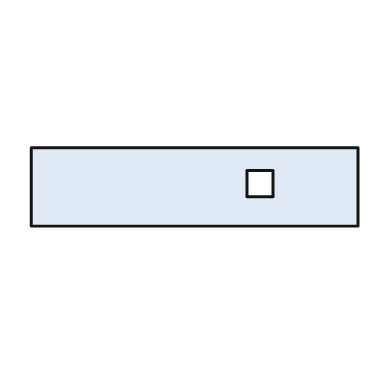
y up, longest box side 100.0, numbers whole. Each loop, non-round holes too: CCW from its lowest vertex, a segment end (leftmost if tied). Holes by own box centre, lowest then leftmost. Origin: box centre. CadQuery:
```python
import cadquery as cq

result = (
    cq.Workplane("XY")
    .moveTo(-50.0, -12.0)
    .lineTo(50.0, -12.0)
    .lineTo(50.0, 12.0)
    .lineTo(-50.0, 12.0)
    .close()
    .moveTo(16.0, -3.0)
    .lineTo(24.0, -3.0)
    .lineTo(24.0, 5.0)
    .lineTo(16.0, 5.0)
    .close()
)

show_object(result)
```